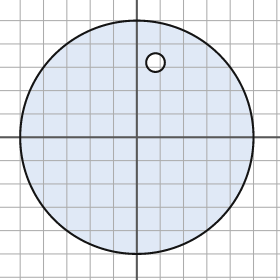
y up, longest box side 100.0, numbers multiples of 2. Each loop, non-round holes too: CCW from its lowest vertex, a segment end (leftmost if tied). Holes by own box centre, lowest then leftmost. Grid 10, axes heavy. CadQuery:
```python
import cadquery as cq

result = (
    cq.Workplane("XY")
    .moveTo(0.0, 0.0)
    .circle(50.0)
    .moveTo(8.0, 32.0)
    .circle(4.0)
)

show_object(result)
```